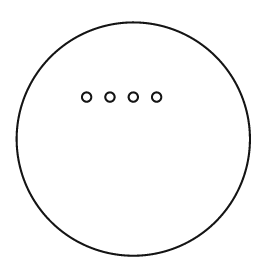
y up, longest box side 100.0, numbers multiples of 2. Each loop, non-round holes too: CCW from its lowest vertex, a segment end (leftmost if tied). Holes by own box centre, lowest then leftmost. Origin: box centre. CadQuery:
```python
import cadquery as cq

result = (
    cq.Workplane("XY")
    .moveTo(0.0, 0.0)
    .circle(50.0)
    .moveTo(-20.0, 18.0)
    .circle(2.0)
    .moveTo(-10.0, 18.0)
    .circle(2.0)
    .moveTo(0.0, 18.0)
    .circle(2.0)
    .moveTo(10.0, 18.0)
    .circle(2.0)
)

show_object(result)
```